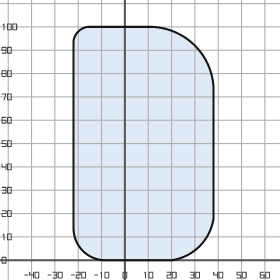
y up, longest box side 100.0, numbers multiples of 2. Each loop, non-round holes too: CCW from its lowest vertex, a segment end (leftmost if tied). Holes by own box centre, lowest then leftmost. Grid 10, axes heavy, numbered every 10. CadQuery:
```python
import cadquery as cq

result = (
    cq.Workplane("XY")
    .moveTo(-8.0, 0.0)
    .lineTo(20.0, 0.0)
    .threePointArc((32.0, 6.0), (38.0, 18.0))
    .lineTo(38.0, 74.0)
    .threePointArc((30.0, 92.0), (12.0, 100.0))
    .lineTo(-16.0, 100.0)
    .threePointArc((-20.0, 98.0), (-22.0, 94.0))
    .lineTo(-22.0, 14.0)
    .threePointArc((-18.0, 4.0), (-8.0, 0.0))
    .close()
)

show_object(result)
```